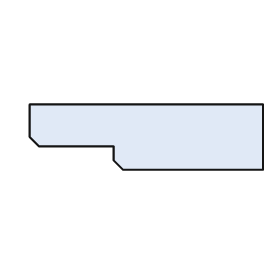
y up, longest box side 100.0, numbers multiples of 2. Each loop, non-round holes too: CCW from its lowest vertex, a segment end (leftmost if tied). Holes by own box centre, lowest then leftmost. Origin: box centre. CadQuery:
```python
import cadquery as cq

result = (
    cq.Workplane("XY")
    .moveTo(-10.0, -14.0)
    .lineTo(50.0, -14.0)
    .lineTo(50.0, 14.0)
    .lineTo(-50.0, 14.0)
    .lineTo(-50.0, 0.0)
    .lineTo(-46.0, -4.0)
    .lineTo(-14.0, -4.0)
    .lineTo(-14.0, -10.0)
    .close()
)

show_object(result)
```